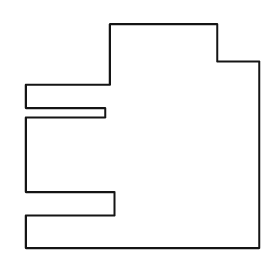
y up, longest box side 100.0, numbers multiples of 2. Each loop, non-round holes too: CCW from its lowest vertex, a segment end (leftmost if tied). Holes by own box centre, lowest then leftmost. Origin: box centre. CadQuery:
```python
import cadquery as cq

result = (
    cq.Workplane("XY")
    .moveTo(-50.0, -48.0)
    .lineTo(50.0, -48.0)
    .lineTo(50.0, 32.0)
    .lineTo(32.0, 32.0)
    .lineTo(32.0, 48.0)
    .lineTo(-14.0, 48.0)
    .lineTo(-14.0, 22.0)
    .lineTo(-50.0, 22.0)
    .lineTo(-50.0, 12.0)
    .lineTo(-16.0, 12.0)
    .lineTo(-16.0, 8.0)
    .lineTo(-50.0, 8.0)
    .lineTo(-50.0, -24.0)
    .lineTo(-12.0, -24.0)
    .lineTo(-12.0, -34.0)
    .lineTo(-50.0, -34.0)
    .close()
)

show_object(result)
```